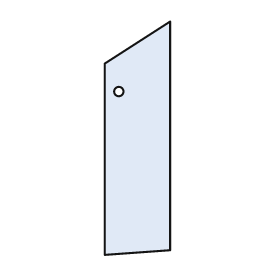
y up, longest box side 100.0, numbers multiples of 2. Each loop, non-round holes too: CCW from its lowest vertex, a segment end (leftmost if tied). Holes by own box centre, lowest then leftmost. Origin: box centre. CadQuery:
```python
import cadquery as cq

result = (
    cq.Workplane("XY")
    .moveTo(-14.0, -50.0)
    .lineTo(14.0, -48.0)
    .lineTo(14.0, 50.0)
    .lineTo(-14.0, 32.0)
    .close()
    .moveTo(-8.0, 20.0)
    .circle(2.0)
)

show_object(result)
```